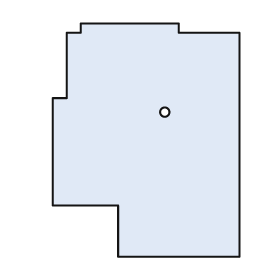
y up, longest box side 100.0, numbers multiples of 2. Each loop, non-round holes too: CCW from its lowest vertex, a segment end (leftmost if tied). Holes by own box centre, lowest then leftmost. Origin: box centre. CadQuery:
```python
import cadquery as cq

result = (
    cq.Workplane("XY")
    .moveTo(-12.0, -50.0)
    .lineTo(40.0, -50.0)
    .lineTo(40.0, 46.0)
    .lineTo(14.0, 46.0)
    .lineTo(14.0, 50.0)
    .lineTo(-28.0, 50.0)
    .lineTo(-28.0, 46.0)
    .lineTo(-34.0, 46.0)
    .lineTo(-34.0, 18.0)
    .lineTo(-40.0, 18.0)
    .lineTo(-40.0, -28.0)
    .lineTo(-12.0, -28.0)
    .close()
    .moveTo(8.0, 12.0)
    .circle(2.0)
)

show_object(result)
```